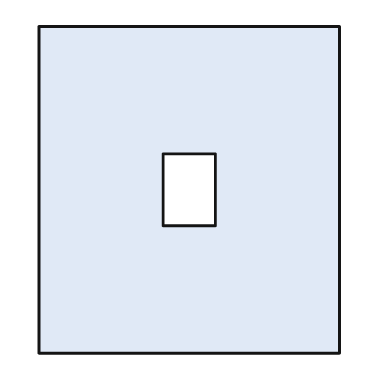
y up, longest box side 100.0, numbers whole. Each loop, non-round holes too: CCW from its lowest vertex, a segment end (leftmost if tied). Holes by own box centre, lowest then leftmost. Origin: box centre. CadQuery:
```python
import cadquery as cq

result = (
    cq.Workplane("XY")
    .moveTo(-46.0, -50.0)
    .lineTo(46.0, -50.0)
    .lineTo(46.0, 50.0)
    .lineTo(-46.0, 50.0)
    .close()
    .moveTo(-8.0, -11.0)
    .lineTo(8.0, -11.0)
    .lineTo(8.0, 11.0)
    .lineTo(-8.0, 11.0)
    .close()
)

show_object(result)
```